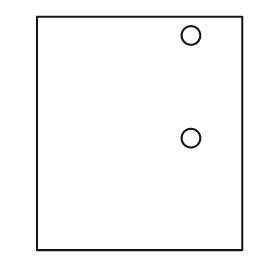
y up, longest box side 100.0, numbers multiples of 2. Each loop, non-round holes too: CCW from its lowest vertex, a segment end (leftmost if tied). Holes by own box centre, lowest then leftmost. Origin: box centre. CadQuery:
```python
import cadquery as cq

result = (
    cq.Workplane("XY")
    .moveTo(-44.0, -50.0)
    .lineTo(44.0, -50.0)
    .lineTo(44.0, 50.0)
    .lineTo(-44.0, 50.0)
    .close()
    .moveTo(22.0, -2.0)
    .circle(4.0)
    .moveTo(22.0, 42.0)
    .circle(4.0)
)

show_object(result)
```